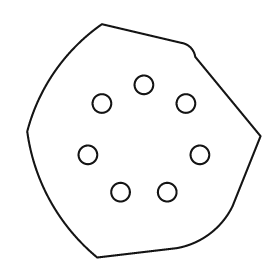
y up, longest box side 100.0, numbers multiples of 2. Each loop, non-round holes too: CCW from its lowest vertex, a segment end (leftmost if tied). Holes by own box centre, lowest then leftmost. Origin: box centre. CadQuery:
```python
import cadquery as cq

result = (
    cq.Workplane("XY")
    .moveTo(-20.0, -50.0)
    .lineTo(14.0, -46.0)
    .threePointArc((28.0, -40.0), (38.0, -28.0))
    .lineTo(50.0, 2.0)
    .lineTo(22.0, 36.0)
    .threePointArc((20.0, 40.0), (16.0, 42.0))
    .lineTo(-18.0, 50.0)
    .threePointArc((-38.0, 30.0), (-50.0, 4.0))
    .threePointArc((-40.0, -26.0), (-20.0, -50.0))
    .close()
    .moveTo(-10.0, -22.0)
    .circle(4.0)
    .moveTo(10.0, -22.0)
    .circle(4.0)
    .moveTo(-24.0, -6.0)
    .circle(4.0)
    .moveTo(24.0, -6.0)
    .circle(4.0)
    .moveTo(-18.0, 16.0)
    .circle(4.0)
    .moveTo(18.0, 16.0)
    .circle(4.0)
    .moveTo(0.0, 24.0)
    .circle(4.0)
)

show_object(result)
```